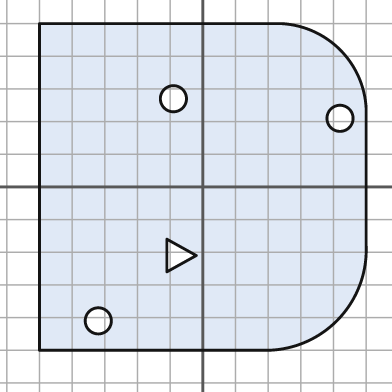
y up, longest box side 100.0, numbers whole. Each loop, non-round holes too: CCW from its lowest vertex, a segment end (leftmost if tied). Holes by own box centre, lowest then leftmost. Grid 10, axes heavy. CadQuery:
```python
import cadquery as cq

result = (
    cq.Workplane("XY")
    .moveTo(-50.0, -50.0)
    .lineTo(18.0, -50.0)
    .threePointArc((41.0, -41.0), (50.0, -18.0))
    .lineTo(50.0, 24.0)
    .threePointArc((42.0, 42.0), (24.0, 50.0))
    .lineTo(-50.0, 50.0)
    .close()
    .moveTo(-32.0, -41.0)
    .circle(4.0)
    .moveTo(-11.0, -26.0)
    .lineTo(-2.0, -21.0)
    .lineTo(-11.0, -16.0)
    .close()
    .moveTo(42.0, 21.0)
    .circle(4.0)
    .moveTo(-9.0, 27.0)
    .circle(4.0)
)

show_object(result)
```